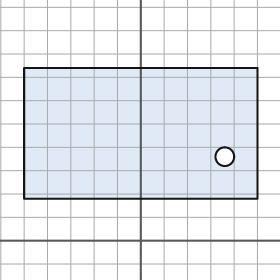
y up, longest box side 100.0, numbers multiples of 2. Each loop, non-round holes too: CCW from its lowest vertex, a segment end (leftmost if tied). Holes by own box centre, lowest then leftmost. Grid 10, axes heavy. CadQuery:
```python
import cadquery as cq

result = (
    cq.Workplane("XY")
    .moveTo(-50.0, 18.0)
    .lineTo(50.0, 18.0)
    .lineTo(50.0, 74.0)
    .lineTo(-50.0, 74.0)
    .close()
    .moveTo(36.0, 36.0)
    .circle(4.0)
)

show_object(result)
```